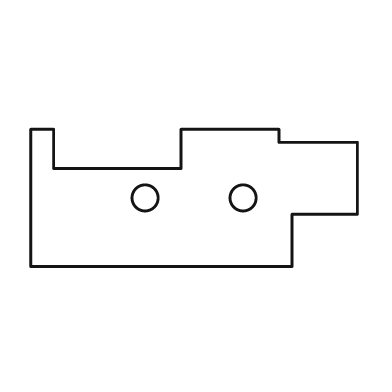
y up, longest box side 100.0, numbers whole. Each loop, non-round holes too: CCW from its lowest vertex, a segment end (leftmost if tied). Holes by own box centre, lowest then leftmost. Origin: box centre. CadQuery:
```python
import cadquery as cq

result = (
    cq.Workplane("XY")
    .moveTo(-50.0, -21.0)
    .lineTo(30.0, -21.0)
    .lineTo(30.0, -5.0)
    .lineTo(50.0, -5.0)
    .lineTo(50.0, 17.0)
    .lineTo(26.0, 17.0)
    .lineTo(26.0, 21.0)
    .lineTo(-4.0, 21.0)
    .lineTo(-4.0, 9.0)
    .lineTo(-43.0, 9.0)
    .lineTo(-43.0, 21.0)
    .lineTo(-50.0, 21.0)
    .close()
    .moveTo(-15.0, 0.0)
    .circle(4.0)
    .moveTo(15.0, 0.0)
    .circle(4.0)
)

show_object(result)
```